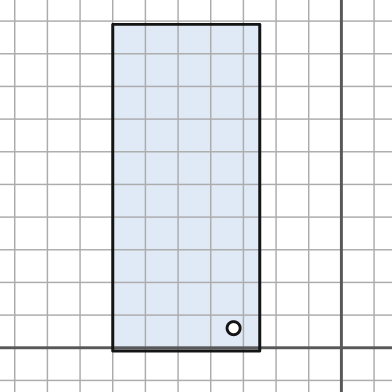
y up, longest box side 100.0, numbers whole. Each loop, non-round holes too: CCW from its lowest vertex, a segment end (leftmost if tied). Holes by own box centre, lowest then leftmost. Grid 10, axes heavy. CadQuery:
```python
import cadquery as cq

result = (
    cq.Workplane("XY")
    .moveTo(-70.0, -1.0)
    .lineTo(-25.0, -1.0)
    .lineTo(-25.0, 99.0)
    .lineTo(-70.0, 99.0)
    .close()
    .moveTo(-33.0, 6.0)
    .circle(2.0)
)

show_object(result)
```